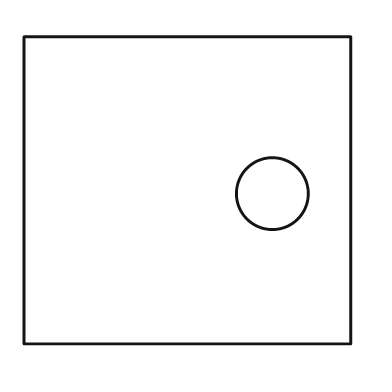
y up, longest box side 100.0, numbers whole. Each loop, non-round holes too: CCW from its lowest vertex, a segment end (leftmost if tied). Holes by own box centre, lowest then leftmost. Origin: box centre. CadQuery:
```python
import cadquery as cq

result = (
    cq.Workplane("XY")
    .moveTo(-50.0, -47.0)
    .lineTo(50.0, -47.0)
    .lineTo(50.0, 47.0)
    .lineTo(-50.0, 47.0)
    .close()
    .moveTo(26.0, -1.0)
    .circle(11.0)
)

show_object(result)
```